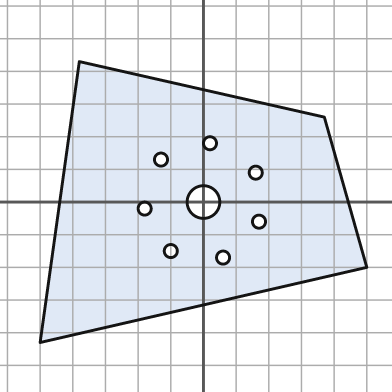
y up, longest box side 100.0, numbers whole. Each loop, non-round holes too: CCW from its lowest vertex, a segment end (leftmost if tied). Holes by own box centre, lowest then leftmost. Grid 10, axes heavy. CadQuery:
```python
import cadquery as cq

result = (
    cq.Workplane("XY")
    .moveTo(-50.0, -43.0)
    .lineTo(50.0, -20.0)
    .lineTo(37.0, 26.0)
    .lineTo(-38.0, 43.0)
    .close()
    .moveTo(6.0, -17.0)
    .circle(2.0)
    .moveTo(-10.0, -15.0)
    .circle(2.0)
    .moveTo(17.0, -6.0)
    .circle(2.0)
    .moveTo(-18.0, -2.0)
    .circle(2.0)
    .moveTo(0.0, 0.0)
    .circle(5.0)
    .moveTo(16.0, 9.0)
    .circle(2.0)
    .moveTo(-13.0, 13.0)
    .circle(2.0)
    .moveTo(2.0, 18.0)
    .circle(2.0)
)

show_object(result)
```